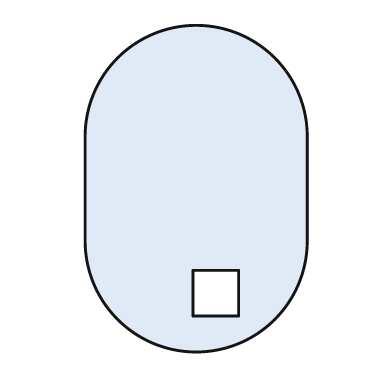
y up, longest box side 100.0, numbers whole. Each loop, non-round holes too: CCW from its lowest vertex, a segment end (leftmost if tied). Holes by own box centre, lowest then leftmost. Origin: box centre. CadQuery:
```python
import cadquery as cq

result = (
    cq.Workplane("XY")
    .moveTo(-34.0, -16.0)
    .threePointArc((0.0, -50.0), (34.0, -16.0))
    .lineTo(34.0, 16.0)
    .threePointArc((0.0, 50.0), (-34.0, 16.0))
    .close()
    .moveTo(-1.0, -39.0)
    .lineTo(13.0, -39.0)
    .lineTo(13.0, -25.0)
    .lineTo(-1.0, -25.0)
    .close()
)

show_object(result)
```